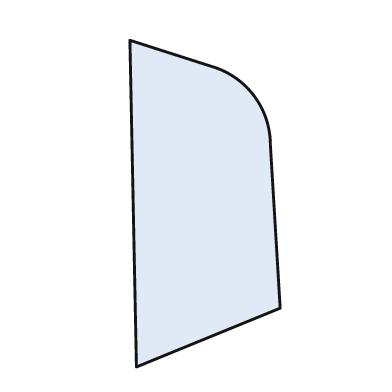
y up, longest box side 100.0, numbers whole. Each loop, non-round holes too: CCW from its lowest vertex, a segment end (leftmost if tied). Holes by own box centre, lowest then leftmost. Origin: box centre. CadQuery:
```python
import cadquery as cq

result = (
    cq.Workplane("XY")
    .moveTo(-21.0, -50.0)
    .lineTo(23.0, -32.0)
    .lineTo(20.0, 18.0)
    .threePointArc((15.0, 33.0), (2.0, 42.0))
    .lineTo(-23.0, 50.0)
    .close()
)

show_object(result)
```